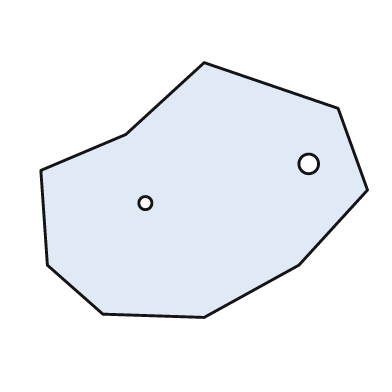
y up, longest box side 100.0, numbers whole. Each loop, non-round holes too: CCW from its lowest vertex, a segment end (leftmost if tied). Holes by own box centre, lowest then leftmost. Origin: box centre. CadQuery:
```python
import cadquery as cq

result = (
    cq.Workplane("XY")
    .moveTo(0.0, -39.0)
    .lineTo(29.0, -23.0)
    .lineTo(50.0, 0.0)
    .lineTo(41.0, 25.0)
    .lineTo(0.0, 39.0)
    .lineTo(-24.0, 17.0)
    .lineTo(-50.0, 6.0)
    .lineTo(-48.0, -23.0)
    .lineTo(-31.0, -38.0)
    .close()
    .moveTo(-18.0, -4.0)
    .circle(2.0)
    .moveTo(32.0, 8.0)
    .circle(3.0)
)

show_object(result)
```